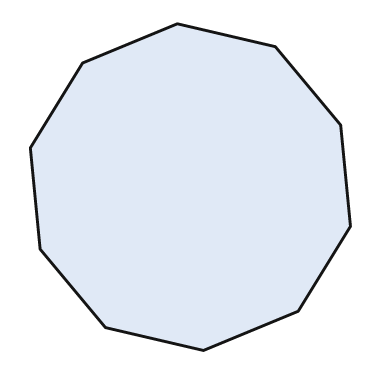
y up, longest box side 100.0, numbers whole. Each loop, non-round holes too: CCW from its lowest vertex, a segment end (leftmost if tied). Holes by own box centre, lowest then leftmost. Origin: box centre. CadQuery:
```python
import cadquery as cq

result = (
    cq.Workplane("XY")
    .moveTo(4.0, -50.0)
    .lineTo(33.0, -38.0)
    .lineTo(49.0, -12.0)
    .lineTo(46.0, 19.0)
    .lineTo(26.0, 43.0)
    .lineTo(-4.0, 50.0)
    .lineTo(-33.0, 38.0)
    .lineTo(-49.0, 12.0)
    .lineTo(-46.0, -19.0)
    .lineTo(-26.0, -43.0)
    .close()
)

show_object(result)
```